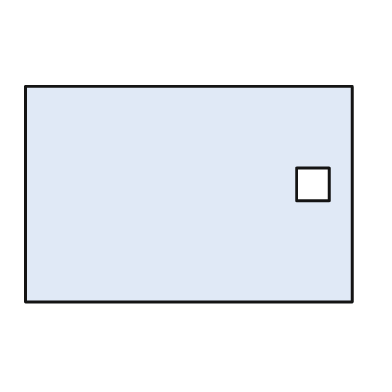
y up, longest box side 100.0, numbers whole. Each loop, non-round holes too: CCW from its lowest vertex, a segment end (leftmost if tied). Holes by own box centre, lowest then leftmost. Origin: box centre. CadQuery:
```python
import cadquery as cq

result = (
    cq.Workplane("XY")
    .moveTo(-50.0, -33.0)
    .lineTo(50.0, -33.0)
    .lineTo(50.0, 33.0)
    .lineTo(-50.0, 33.0)
    .close()
    .moveTo(33.0, -2.0)
    .lineTo(43.0, -2.0)
    .lineTo(43.0, 8.0)
    .lineTo(33.0, 8.0)
    .close()
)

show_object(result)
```